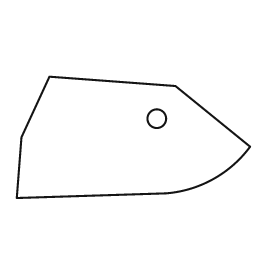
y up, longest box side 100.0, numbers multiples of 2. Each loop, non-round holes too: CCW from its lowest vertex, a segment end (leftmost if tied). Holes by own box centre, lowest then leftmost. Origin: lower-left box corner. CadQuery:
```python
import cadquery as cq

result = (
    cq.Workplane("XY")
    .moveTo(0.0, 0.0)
    .lineTo(64.0, 2.0)
    .threePointArc((84.0, 8.0), (100.0, 22.0))
    .lineTo(68.0, 48.0)
    .lineTo(14.0, 52.0)
    .lineTo(2.0, 26.0)
    .close()
    .moveTo(60.0, 34.0)
    .circle(4.0)
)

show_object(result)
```